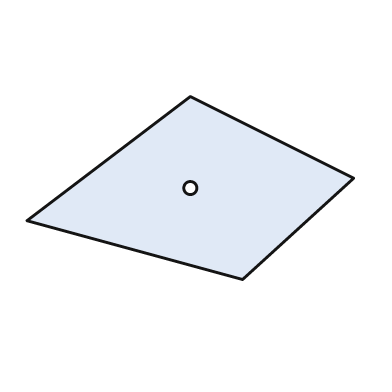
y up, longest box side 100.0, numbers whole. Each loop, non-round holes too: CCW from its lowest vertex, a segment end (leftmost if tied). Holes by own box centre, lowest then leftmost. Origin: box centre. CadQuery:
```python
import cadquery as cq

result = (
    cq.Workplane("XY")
    .moveTo(16.0, -28.0)
    .lineTo(50.0, 3.0)
    .lineTo(0.0, 28.0)
    .lineTo(-50.0, -10.0)
    .close()
    .moveTo(0.0, 0.0)
    .circle(2.0)
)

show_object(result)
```